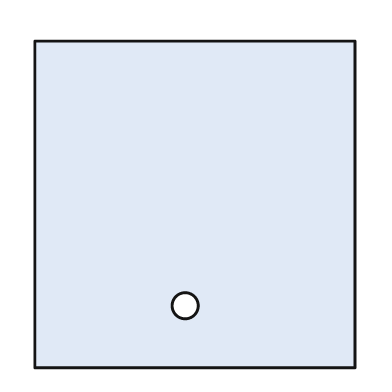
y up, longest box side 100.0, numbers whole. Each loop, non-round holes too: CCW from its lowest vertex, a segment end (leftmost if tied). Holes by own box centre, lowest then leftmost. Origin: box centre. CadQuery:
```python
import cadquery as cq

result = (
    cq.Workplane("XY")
    .moveTo(-49.0, -50.0)
    .lineTo(49.0, -50.0)
    .lineTo(49.0, 50.0)
    .lineTo(-49.0, 50.0)
    .close()
    .moveTo(-3.0, -31.0)
    .circle(4.0)
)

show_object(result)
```